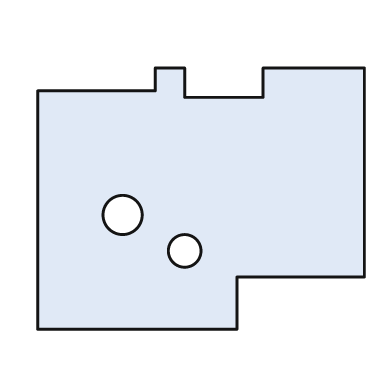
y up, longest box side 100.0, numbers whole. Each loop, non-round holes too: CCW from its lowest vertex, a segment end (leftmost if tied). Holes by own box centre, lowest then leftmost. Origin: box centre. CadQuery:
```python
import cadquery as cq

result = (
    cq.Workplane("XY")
    .moveTo(-50.0, -40.0)
    .lineTo(11.0, -40.0)
    .lineTo(11.0, -24.0)
    .lineTo(50.0, -24.0)
    .lineTo(50.0, 40.0)
    .lineTo(19.0, 40.0)
    .lineTo(19.0, 31.0)
    .lineTo(-5.0, 31.0)
    .lineTo(-5.0, 40.0)
    .lineTo(-14.0, 40.0)
    .lineTo(-14.0, 33.0)
    .lineTo(-50.0, 33.0)
    .close()
    .moveTo(-5.0, -16.0)
    .circle(5.0)
    .moveTo(-24.0, -5.0)
    .circle(6.0)
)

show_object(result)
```